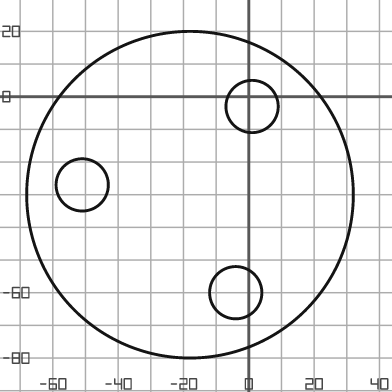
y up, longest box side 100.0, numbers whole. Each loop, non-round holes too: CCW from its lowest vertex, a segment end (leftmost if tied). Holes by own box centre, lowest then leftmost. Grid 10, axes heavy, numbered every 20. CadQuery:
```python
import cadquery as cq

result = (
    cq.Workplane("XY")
    .moveTo(-18.0, -30.0)
    .circle(50.0)
    .moveTo(-4.0, -60.0)
    .circle(8.0)
    .moveTo(-51.0, -27.0)
    .circle(8.0)
    .moveTo(1.0, -3.0)
    .circle(8.0)
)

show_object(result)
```